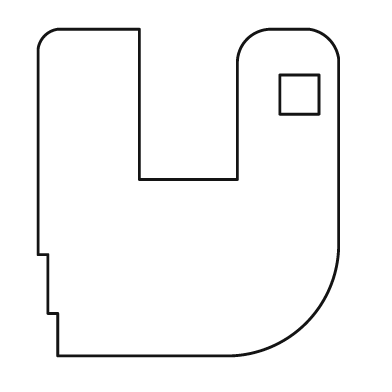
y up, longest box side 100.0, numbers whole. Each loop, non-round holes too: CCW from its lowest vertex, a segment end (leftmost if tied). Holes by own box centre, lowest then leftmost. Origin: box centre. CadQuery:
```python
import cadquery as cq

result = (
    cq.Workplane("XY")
    .moveTo(-40.0, -50.0)
    .lineTo(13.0, -50.0)
    .threePointArc((36.0, -40.0), (46.0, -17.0))
    .lineTo(46.0, 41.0)
    .threePointArc((43.0, 47.0), (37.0, 50.0))
    .lineTo(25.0, 50.0)
    .threePointArc((18.0, 47.0), (15.0, 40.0))
    .lineTo(15.0, 4.0)
    .lineTo(-15.0, 4.0)
    .lineTo(-15.0, 50.0)
    .lineTo(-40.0, 50.0)
    .threePointArc((-44.0, 48.0), (-46.0, 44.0))
    .lineTo(-46.0, -19.0)
    .lineTo(-43.0, -19.0)
    .lineTo(-43.0, -37.0)
    .lineTo(-40.0, -37.0)
    .close()
    .moveTo(28.0, 24.0)
    .lineTo(40.0, 24.0)
    .lineTo(40.0, 36.0)
    .lineTo(28.0, 36.0)
    .close()
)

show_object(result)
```